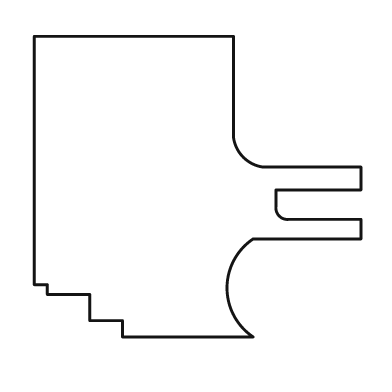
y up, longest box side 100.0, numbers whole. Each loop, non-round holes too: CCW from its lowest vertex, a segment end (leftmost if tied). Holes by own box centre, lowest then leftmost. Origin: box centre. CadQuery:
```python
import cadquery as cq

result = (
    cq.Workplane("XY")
    .moveTo(-23.0, -46.0)
    .lineTo(17.0, -46.0)
    .threePointArc((9.0, -31.0), (17.0, -16.0))
    .lineTo(50.0, -16.0)
    .lineTo(50.0, -10.0)
    .lineTo(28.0, -10.0)
    .threePointArc((25.0, -9.0), (24.0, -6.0))
    .lineTo(24.0, -1.0)
    .lineTo(50.0, -1.0)
    .lineTo(50.0, 6.0)
    .lineTo(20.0, 6.0)
    .threePointArc((14.0, 9.0), (11.0, 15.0))
    .lineTo(11.0, 46.0)
    .lineTo(-50.0, 46.0)
    .lineTo(-50.0, -30.0)
    .lineTo(-46.0, -30.0)
    .lineTo(-46.0, -33.0)
    .lineTo(-33.0, -33.0)
    .lineTo(-33.0, -41.0)
    .lineTo(-23.0, -41.0)
    .close()
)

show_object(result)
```